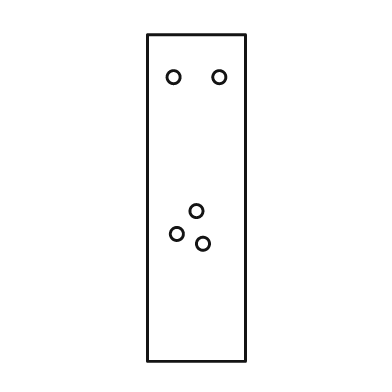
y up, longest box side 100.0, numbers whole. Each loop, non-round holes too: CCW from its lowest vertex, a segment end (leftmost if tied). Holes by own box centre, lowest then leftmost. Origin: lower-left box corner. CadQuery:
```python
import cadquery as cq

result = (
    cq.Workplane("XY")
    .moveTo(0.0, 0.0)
    .lineTo(30.0, 0.0)
    .lineTo(30.0, 100.0)
    .lineTo(0.0, 100.0)
    .close()
    .moveTo(17.0, 36.0)
    .circle(2.0)
    .moveTo(9.0, 39.0)
    .circle(2.0)
    .moveTo(15.0, 46.0)
    .circle(2.0)
    .moveTo(8.0, 87.0)
    .circle(2.0)
    .moveTo(22.0, 87.0)
    .circle(2.0)
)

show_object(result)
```